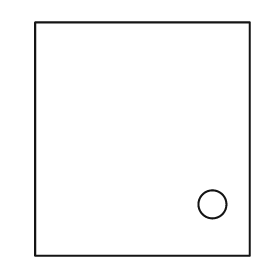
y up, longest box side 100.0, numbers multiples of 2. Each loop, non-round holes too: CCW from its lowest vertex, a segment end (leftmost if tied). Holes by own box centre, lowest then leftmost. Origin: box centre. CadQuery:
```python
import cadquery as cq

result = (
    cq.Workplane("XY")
    .moveTo(-46.0, -50.0)
    .lineTo(46.0, -50.0)
    .lineTo(46.0, 50.0)
    .lineTo(-46.0, 50.0)
    .close()
    .moveTo(30.0, -28.0)
    .circle(6.0)
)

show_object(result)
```